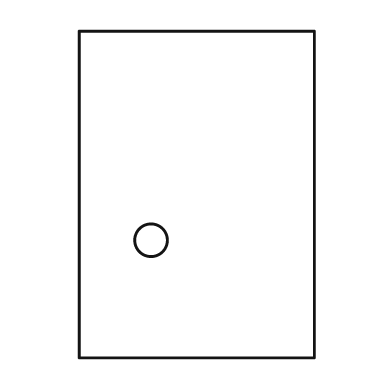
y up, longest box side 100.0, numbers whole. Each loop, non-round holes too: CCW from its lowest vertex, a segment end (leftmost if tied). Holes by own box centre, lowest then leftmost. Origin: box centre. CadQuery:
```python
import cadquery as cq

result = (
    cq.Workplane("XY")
    .moveTo(-36.0, -50.0)
    .lineTo(36.0, -50.0)
    .lineTo(36.0, 50.0)
    .lineTo(-36.0, 50.0)
    .close()
    .moveTo(-14.0, -14.0)
    .circle(5.0)
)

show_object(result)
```